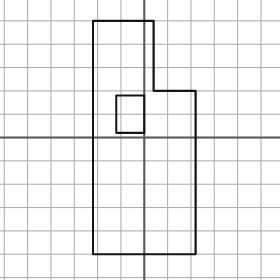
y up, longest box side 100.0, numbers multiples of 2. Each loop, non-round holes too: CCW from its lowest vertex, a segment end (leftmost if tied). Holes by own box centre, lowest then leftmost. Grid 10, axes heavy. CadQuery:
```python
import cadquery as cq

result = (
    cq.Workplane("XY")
    .moveTo(-22.0, -50.0)
    .lineTo(22.0, -50.0)
    .lineTo(22.0, 20.0)
    .lineTo(4.0, 20.0)
    .lineTo(4.0, 50.0)
    .lineTo(-22.0, 50.0)
    .close()
    .moveTo(-12.0, 2.0)
    .lineTo(0.0, 2.0)
    .lineTo(0.0, 18.0)
    .lineTo(-12.0, 18.0)
    .close()
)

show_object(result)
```